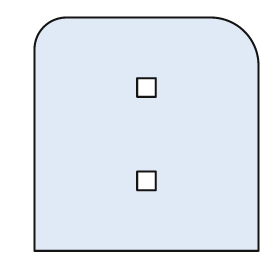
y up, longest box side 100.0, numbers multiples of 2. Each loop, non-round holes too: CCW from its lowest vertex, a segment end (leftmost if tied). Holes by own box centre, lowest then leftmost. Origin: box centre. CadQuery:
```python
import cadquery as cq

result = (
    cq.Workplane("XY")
    .moveTo(-48.0, -50.0)
    .lineTo(48.0, -50.0)
    .lineTo(48.0, 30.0)
    .threePointArc((42.0, 44.0), (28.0, 50.0))
    .lineTo(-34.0, 50.0)
    .threePointArc((-44.0, 46.0), (-48.0, 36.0))
    .close()
    .moveTo(-4.0, -24.0)
    .lineTo(4.0, -24.0)
    .lineTo(4.0, -16.0)
    .lineTo(-4.0, -16.0)
    .close()
    .moveTo(-4.0, 16.0)
    .lineTo(4.0, 16.0)
    .lineTo(4.0, 24.0)
    .lineTo(-4.0, 24.0)
    .close()
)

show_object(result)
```